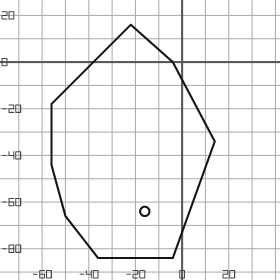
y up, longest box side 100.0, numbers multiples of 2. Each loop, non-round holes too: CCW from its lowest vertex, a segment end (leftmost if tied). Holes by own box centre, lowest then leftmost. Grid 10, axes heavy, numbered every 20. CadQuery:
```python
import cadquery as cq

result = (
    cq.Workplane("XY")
    .moveTo(-36.0, -84.0)
    .lineTo(-4.0, -84.0)
    .lineTo(14.0, -34.0)
    .lineTo(-4.0, 0.0)
    .lineTo(-22.0, 16.0)
    .lineTo(-56.0, -18.0)
    .lineTo(-56.0, -44.0)
    .lineTo(-50.0, -66.0)
    .close()
    .moveTo(-16.0, -64.0)
    .circle(2.0)
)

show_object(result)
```